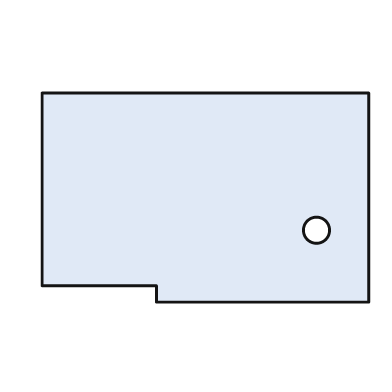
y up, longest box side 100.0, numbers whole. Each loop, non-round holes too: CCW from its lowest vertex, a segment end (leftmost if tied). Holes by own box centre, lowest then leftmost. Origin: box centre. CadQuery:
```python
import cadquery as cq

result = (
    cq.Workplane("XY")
    .moveTo(-15.0, -32.0)
    .lineTo(50.0, -32.0)
    .lineTo(50.0, 32.0)
    .lineTo(-50.0, 32.0)
    .lineTo(-50.0, -27.0)
    .lineTo(-15.0, -27.0)
    .close()
    .moveTo(34.0, -10.0)
    .circle(4.0)
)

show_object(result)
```